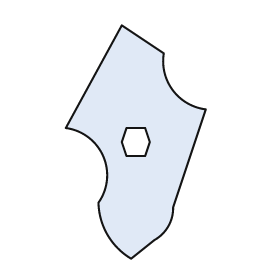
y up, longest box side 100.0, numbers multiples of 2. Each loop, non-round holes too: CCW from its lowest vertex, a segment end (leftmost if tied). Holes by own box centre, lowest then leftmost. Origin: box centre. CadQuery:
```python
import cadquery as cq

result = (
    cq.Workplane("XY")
    .moveTo(-2.0, -50.0)
    .lineTo(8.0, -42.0)
    .threePointArc((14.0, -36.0), (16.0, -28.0))
    .lineTo(30.0, 14.0)
    .threePointArc((16.0, 22.0), (12.0, 38.0))
    .lineTo(-6.0, 50.0)
    .lineTo(-30.0, 6.0)
    .threePointArc((-14.0, -6.0), (-16.0, -26.0))
    .threePointArc((-12.0, -40.0), (-2.0, -50.0))
    .close()
    .moveTo(-4.0, -6.0)
    .lineTo(4.0, -6.0)
    .lineTo(6.0, 0.0)
    .lineTo(4.0, 6.0)
    .lineTo(-4.0, 6.0)
    .lineTo(-6.0, 0.0)
    .close()
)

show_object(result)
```